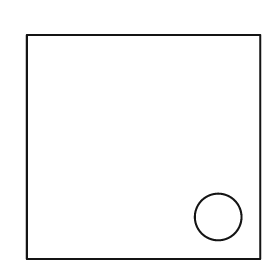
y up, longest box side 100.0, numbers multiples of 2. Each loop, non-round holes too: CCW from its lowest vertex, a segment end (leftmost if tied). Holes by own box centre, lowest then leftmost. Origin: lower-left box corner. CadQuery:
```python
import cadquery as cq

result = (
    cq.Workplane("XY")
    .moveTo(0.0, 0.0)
    .lineTo(100.0, 0.0)
    .lineTo(100.0, 96.0)
    .lineTo(0.0, 96.0)
    .close()
    .moveTo(82.0, 18.0)
    .circle(10.0)
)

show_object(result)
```